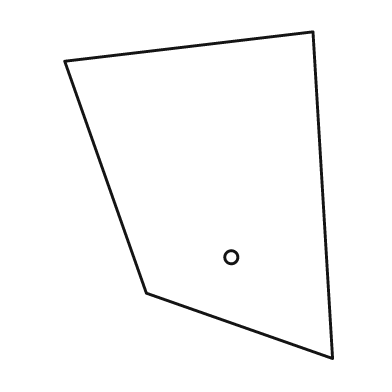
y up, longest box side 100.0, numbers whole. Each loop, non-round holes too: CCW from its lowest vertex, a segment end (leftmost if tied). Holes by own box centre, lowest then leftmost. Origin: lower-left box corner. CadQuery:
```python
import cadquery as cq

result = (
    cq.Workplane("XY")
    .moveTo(82.0, 0.0)
    .lineTo(76.0, 100.0)
    .lineTo(0.0, 91.0)
    .lineTo(25.0, 20.0)
    .close()
    .moveTo(51.0, 31.0)
    .circle(2.0)
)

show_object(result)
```